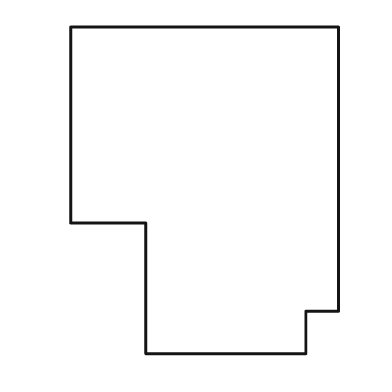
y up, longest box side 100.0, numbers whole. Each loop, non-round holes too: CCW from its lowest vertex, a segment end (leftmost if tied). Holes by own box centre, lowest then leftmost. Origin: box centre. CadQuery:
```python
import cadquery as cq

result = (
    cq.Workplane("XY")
    .moveTo(-18.0, -50.0)
    .lineTo(31.0, -50.0)
    .lineTo(31.0, -37.0)
    .lineTo(41.0, -37.0)
    .lineTo(41.0, 50.0)
    .lineTo(-41.0, 50.0)
    .lineTo(-41.0, -10.0)
    .lineTo(-18.0, -10.0)
    .close()
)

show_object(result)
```